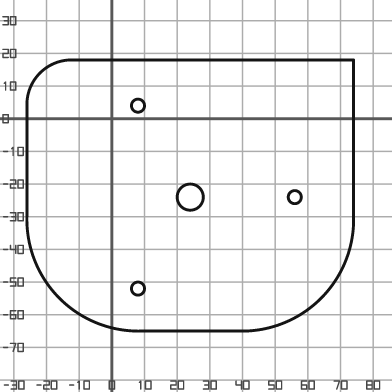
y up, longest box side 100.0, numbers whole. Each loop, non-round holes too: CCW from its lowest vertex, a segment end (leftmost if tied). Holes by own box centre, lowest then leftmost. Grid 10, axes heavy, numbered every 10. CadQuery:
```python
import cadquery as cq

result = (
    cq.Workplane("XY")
    .moveTo(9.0, -65.0)
    .lineTo(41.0, -65.0)
    .threePointArc((64.0, -55.0), (74.0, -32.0))
    .lineTo(74.0, 18.0)
    .lineTo(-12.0, 18.0)
    .threePointArc((-22.0, 14.0), (-26.0, 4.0))
    .lineTo(-26.0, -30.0)
    .threePointArc((-16.0, -55.0), (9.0, -65.0))
    .close()
    .moveTo(8.0, -52.0)
    .circle(2.0)
    .moveTo(24.0, -24.0)
    .circle(4.0)
    .moveTo(56.0, -24.0)
    .circle(2.0)
    .moveTo(8.0, 4.0)
    .circle(2.0)
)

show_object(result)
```